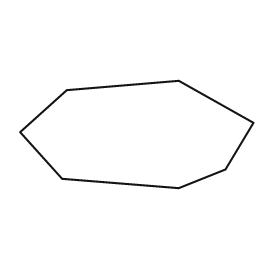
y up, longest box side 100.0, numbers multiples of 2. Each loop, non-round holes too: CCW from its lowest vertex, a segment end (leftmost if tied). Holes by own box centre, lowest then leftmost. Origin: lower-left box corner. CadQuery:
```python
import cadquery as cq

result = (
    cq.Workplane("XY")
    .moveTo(68.0, 0.0)
    .lineTo(88.0, 8.0)
    .lineTo(100.0, 28.0)
    .lineTo(68.0, 46.0)
    .lineTo(20.0, 42.0)
    .lineTo(0.0, 24.0)
    .lineTo(18.0, 4.0)
    .close()
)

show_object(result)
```